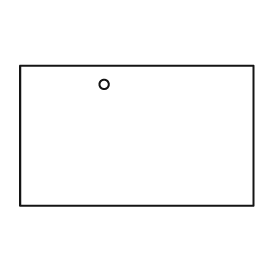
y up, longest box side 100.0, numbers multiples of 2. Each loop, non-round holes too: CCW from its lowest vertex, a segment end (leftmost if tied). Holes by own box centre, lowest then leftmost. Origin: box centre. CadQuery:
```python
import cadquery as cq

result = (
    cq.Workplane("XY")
    .moveTo(-50.0, -30.0)
    .lineTo(50.0, -30.0)
    .lineTo(50.0, 30.0)
    .lineTo(-50.0, 30.0)
    .close()
    .moveTo(-14.0, 22.0)
    .circle(2.0)
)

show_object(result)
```